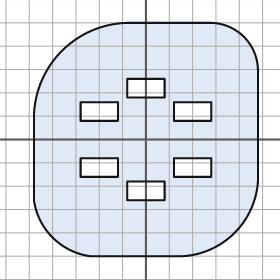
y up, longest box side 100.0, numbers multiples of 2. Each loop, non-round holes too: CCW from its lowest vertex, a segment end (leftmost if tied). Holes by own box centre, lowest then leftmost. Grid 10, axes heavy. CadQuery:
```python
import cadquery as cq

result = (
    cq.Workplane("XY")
    .moveTo(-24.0, -50.0)
    .lineTo(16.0, -50.0)
    .threePointArc((38.0, -40.0), (48.0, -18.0))
    .lineTo(48.0, 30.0)
    .threePointArc((42.0, 44.0), (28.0, 50.0))
    .lineTo(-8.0, 50.0)
    .threePointArc((-36.0, 38.0), (-48.0, 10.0))
    .lineTo(-48.0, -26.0)
    .threePointArc((-40.0, -42.0), (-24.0, -50.0))
    .close()
    .moveTo(-8.0, -26.0)
    .lineTo(8.0, -26.0)
    .lineTo(8.0, -18.0)
    .lineTo(-8.0, -18.0)
    .close()
    .moveTo(-28.0, -16.0)
    .lineTo(-12.0, -16.0)
    .lineTo(-12.0, -8.0)
    .lineTo(-28.0, -8.0)
    .close()
    .moveTo(12.0, -16.0)
    .lineTo(28.0, -16.0)
    .lineTo(28.0, -8.0)
    .lineTo(12.0, -8.0)
    .close()
    .moveTo(-28.0, 8.0)
    .lineTo(-12.0, 8.0)
    .lineTo(-12.0, 16.0)
    .lineTo(-28.0, 16.0)
    .close()
    .moveTo(12.0, 8.0)
    .lineTo(28.0, 8.0)
    .lineTo(28.0, 16.0)
    .lineTo(12.0, 16.0)
    .close()
    .moveTo(-8.0, 18.0)
    .lineTo(8.0, 18.0)
    .lineTo(8.0, 26.0)
    .lineTo(-8.0, 26.0)
    .close()
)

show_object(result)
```